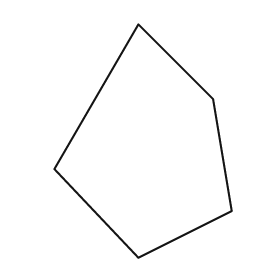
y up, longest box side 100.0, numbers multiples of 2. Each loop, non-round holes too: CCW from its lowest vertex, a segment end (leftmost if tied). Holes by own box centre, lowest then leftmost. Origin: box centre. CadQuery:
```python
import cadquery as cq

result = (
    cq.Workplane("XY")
    .moveTo(-2.0, -50.0)
    .lineTo(38.0, -30.0)
    .lineTo(30.0, 18.0)
    .lineTo(-2.0, 50.0)
    .lineTo(-38.0, -12.0)
    .close()
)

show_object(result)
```